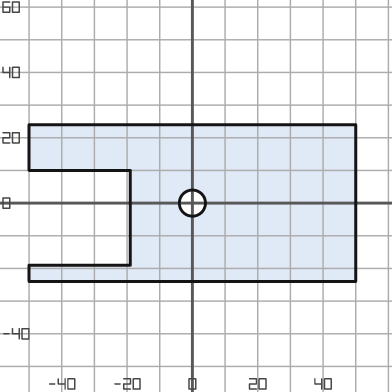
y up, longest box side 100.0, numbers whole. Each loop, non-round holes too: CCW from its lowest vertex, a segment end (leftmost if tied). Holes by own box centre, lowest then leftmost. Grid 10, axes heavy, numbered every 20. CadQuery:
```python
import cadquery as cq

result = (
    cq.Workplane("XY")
    .moveTo(-50.0, -24.0)
    .lineTo(50.0, -24.0)
    .lineTo(50.0, 24.0)
    .lineTo(-50.0, 24.0)
    .lineTo(-50.0, 10.0)
    .lineTo(-19.0, 10.0)
    .lineTo(-19.0, -19.0)
    .lineTo(-50.0, -19.0)
    .close()
    .moveTo(0.0, 0.0)
    .circle(4.0)
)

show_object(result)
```